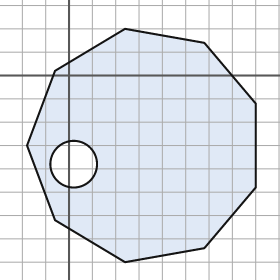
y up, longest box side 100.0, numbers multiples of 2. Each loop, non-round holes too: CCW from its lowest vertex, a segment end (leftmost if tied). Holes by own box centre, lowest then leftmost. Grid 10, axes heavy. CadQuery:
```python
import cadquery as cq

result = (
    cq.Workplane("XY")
    .moveTo(24.0, -80.0)
    .lineTo(58.0, -74.0)
    .lineTo(80.0, -48.0)
    .lineTo(80.0, -12.0)
    .lineTo(58.0, 14.0)
    .lineTo(24.0, 20.0)
    .lineTo(-6.0, 2.0)
    .lineTo(-18.0, -30.0)
    .lineTo(-6.0, -62.0)
    .close()
    .moveTo(2.0, -38.0)
    .circle(10.0)
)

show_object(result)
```